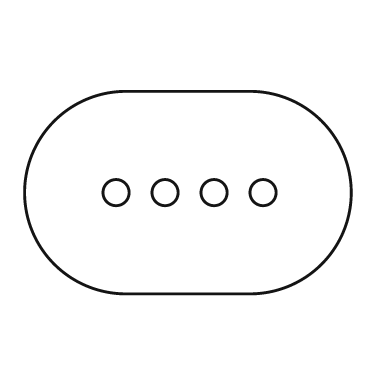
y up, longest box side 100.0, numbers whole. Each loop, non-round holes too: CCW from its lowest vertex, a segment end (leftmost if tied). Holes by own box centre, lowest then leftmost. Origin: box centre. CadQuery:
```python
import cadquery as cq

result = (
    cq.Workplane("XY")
    .moveTo(-19.0, -31.0)
    .lineTo(19.0, -31.0)
    .threePointArc((50.0, 0.0), (19.0, 31.0))
    .lineTo(-19.0, 31.0)
    .threePointArc((-50.0, 0.0), (-19.0, -31.0))
    .close()
    .moveTo(-22.0, 0.0)
    .circle(4.0)
    .moveTo(-7.0, 0.0)
    .circle(4.0)
    .moveTo(8.0, 0.0)
    .circle(4.0)
    .moveTo(23.0, 0.0)
    .circle(4.0)
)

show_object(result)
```